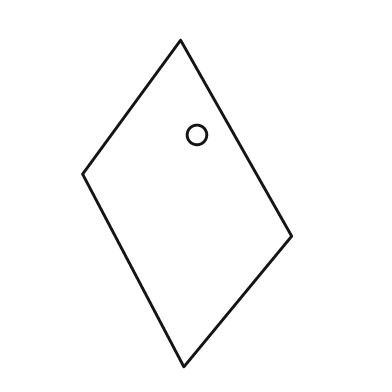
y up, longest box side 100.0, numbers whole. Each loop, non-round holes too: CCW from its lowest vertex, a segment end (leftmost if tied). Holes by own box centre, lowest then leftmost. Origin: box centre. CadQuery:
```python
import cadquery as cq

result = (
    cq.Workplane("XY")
    .moveTo(-1.0, -50.0)
    .lineTo(32.0, -10.0)
    .lineTo(-2.0, 50.0)
    .lineTo(-32.0, 9.0)
    .close()
    .moveTo(3.0, 21.0)
    .circle(3.0)
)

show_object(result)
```